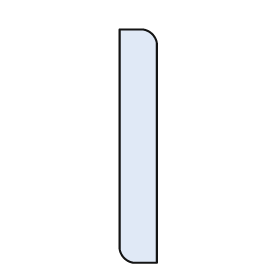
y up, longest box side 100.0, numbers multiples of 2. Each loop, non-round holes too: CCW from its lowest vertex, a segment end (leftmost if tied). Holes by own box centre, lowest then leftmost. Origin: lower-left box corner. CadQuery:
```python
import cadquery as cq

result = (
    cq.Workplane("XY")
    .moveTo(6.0, 0.0)
    .lineTo(16.0, 0.0)
    .lineTo(16.0, 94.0)
    .threePointArc((14.0, 98.0), (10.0, 100.0))
    .lineTo(0.0, 100.0)
    .lineTo(0.0, 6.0)
    .threePointArc((2.0, 2.0), (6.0, 0.0))
    .close()
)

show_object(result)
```